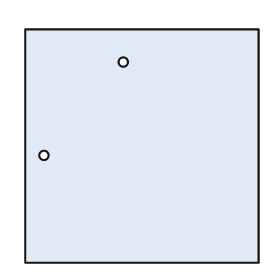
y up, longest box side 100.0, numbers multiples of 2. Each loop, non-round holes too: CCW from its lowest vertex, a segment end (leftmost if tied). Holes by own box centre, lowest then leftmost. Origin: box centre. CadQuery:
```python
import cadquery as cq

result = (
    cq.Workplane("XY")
    .moveTo(-50.0, -50.0)
    .lineTo(50.0, -50.0)
    .lineTo(50.0, 50.0)
    .lineTo(-50.0, 50.0)
    .close()
    .moveTo(-42.0, -4.0)
    .circle(2.0)
    .moveTo(-8.0, 36.0)
    .circle(2.0)
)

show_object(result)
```